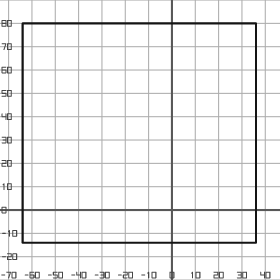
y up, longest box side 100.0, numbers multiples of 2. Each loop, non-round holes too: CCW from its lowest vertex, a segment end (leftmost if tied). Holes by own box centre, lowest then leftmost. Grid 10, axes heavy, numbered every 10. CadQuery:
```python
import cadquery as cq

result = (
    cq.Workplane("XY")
    .moveTo(-64.0, -14.0)
    .lineTo(36.0, -14.0)
    .lineTo(36.0, 80.0)
    .lineTo(-64.0, 80.0)
    .close()
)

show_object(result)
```